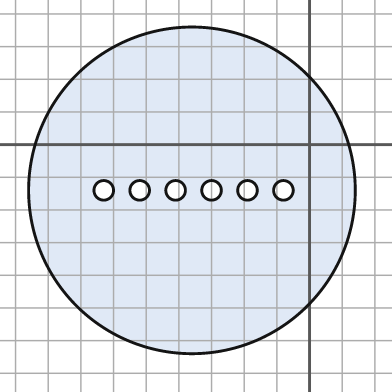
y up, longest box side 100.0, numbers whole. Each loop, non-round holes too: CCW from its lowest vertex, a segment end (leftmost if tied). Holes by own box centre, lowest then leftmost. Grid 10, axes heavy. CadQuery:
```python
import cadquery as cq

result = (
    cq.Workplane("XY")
    .moveTo(-36.0, -14.0)
    .circle(50.0)
    .moveTo(-63.0, -14.0)
    .circle(3.0)
    .moveTo(-52.0, -14.0)
    .circle(3.0)
    .moveTo(-41.0, -14.0)
    .circle(3.0)
    .moveTo(-30.0, -14.0)
    .circle(3.0)
    .moveTo(-19.0, -14.0)
    .circle(3.0)
    .moveTo(-8.0, -14.0)
    .circle(3.0)
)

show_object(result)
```